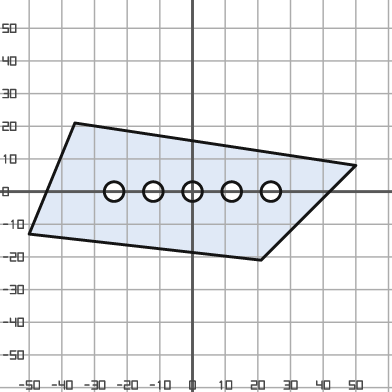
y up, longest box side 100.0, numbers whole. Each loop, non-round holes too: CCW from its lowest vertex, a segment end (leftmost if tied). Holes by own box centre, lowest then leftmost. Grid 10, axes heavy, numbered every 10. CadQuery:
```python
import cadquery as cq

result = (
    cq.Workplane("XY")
    .moveTo(21.0, -21.0)
    .lineTo(50.0, 8.0)
    .lineTo(-36.0, 21.0)
    .lineTo(-50.0, -13.0)
    .close()
    .moveTo(-24.0, 0.0)
    .circle(3.0)
    .moveTo(-12.0, 0.0)
    .circle(3.0)
    .moveTo(0.0, 0.0)
    .circle(3.0)
    .moveTo(12.0, 0.0)
    .circle(3.0)
    .moveTo(24.0, 0.0)
    .circle(3.0)
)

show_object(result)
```